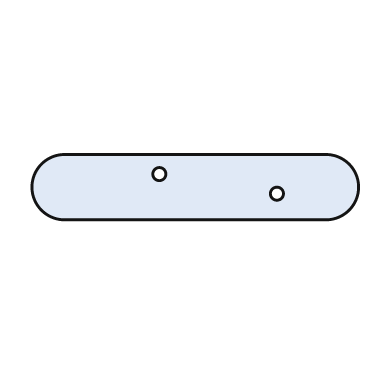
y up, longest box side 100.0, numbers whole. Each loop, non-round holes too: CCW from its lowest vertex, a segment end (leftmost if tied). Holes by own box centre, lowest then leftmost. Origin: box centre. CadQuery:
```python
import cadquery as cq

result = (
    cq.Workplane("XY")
    .moveTo(-40.0, -10.0)
    .lineTo(40.0, -10.0)
    .threePointArc((50.0, 0.0), (40.0, 10.0))
    .lineTo(-40.0, 10.0)
    .threePointArc((-50.0, 0.0), (-40.0, -10.0))
    .close()
    .moveTo(25.0, -2.0)
    .circle(2.0)
    .moveTo(-11.0, 4.0)
    .circle(2.0)
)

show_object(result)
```